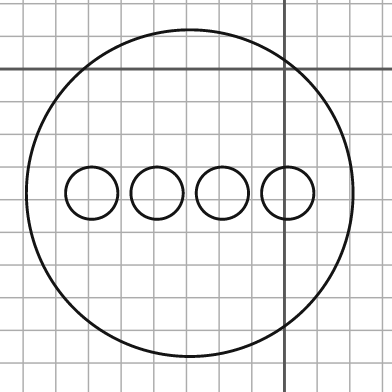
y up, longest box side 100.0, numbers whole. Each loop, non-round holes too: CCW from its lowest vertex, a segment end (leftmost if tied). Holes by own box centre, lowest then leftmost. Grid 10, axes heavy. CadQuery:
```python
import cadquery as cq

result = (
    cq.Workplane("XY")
    .moveTo(-29.0, -38.0)
    .circle(50.0)
    .moveTo(-59.0, -38.0)
    .circle(8.0)
    .moveTo(-39.0, -38.0)
    .circle(8.0)
    .moveTo(-19.0, -38.0)
    .circle(8.0)
    .moveTo(1.0, -38.0)
    .circle(8.0)
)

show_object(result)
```